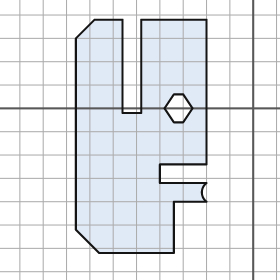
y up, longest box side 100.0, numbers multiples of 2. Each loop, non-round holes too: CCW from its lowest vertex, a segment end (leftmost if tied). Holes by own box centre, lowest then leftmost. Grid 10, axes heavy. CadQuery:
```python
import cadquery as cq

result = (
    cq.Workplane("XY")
    .moveTo(-66.0, -62.0)
    .lineTo(-34.0, -62.0)
    .lineTo(-34.0, -40.0)
    .lineTo(-20.0, -40.0)
    .threePointArc((-22.0, -36.0), (-20.0, -32.0))
    .lineTo(-40.0, -32.0)
    .lineTo(-40.0, -24.0)
    .lineTo(-20.0, -24.0)
    .lineTo(-20.0, 38.0)
    .lineTo(-48.0, 38.0)
    .lineTo(-48.0, -2.0)
    .lineTo(-56.0, -2.0)
    .lineTo(-56.0, 38.0)
    .lineTo(-68.0, 38.0)
    .lineTo(-76.0, 30.0)
    .lineTo(-76.0, -52.0)
    .close()
    .moveTo(-34.0, -6.0)
    .lineTo(-30.0, -6.0)
    .lineTo(-26.0, 0.0)
    .lineTo(-30.0, 6.0)
    .lineTo(-34.0, 6.0)
    .lineTo(-38.0, 0.0)
    .close()
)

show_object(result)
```